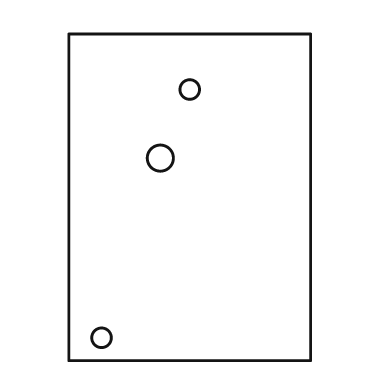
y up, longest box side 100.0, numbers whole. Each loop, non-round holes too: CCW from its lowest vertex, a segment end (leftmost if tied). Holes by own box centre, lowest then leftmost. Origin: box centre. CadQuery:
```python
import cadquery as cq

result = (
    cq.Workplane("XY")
    .moveTo(-37.0, -50.0)
    .lineTo(37.0, -50.0)
    .lineTo(37.0, 50.0)
    .lineTo(-37.0, 50.0)
    .close()
    .moveTo(-27.0, -43.0)
    .circle(3.0)
    .moveTo(-9.0, 12.0)
    .circle(4.0)
    .moveTo(0.0, 33.0)
    .circle(3.0)
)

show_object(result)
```